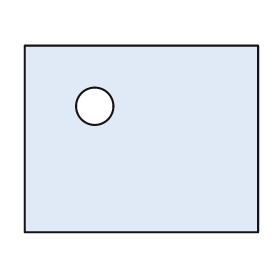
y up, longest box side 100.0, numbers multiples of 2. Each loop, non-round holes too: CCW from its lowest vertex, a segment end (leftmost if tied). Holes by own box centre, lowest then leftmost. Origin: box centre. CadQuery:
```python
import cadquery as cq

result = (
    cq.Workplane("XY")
    .moveTo(-50.0, -40.0)
    .lineTo(50.0, -40.0)
    .lineTo(50.0, 40.0)
    .lineTo(-50.0, 40.0)
    .close()
    .moveTo(-20.0, 14.0)
    .circle(8.0)
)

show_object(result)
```